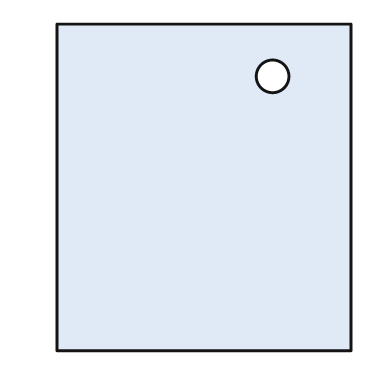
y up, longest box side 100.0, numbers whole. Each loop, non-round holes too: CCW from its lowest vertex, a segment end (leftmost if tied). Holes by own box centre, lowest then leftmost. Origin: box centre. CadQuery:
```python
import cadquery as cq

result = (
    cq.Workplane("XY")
    .moveTo(-45.0, -50.0)
    .lineTo(45.0, -50.0)
    .lineTo(45.0, 50.0)
    .lineTo(-45.0, 50.0)
    .close()
    .moveTo(21.0, 34.0)
    .circle(5.0)
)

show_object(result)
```